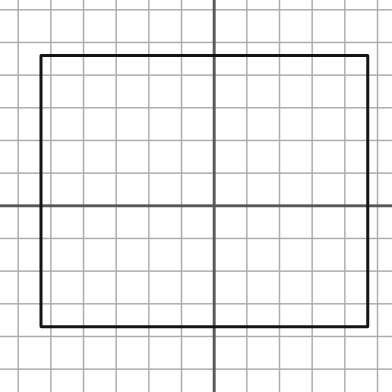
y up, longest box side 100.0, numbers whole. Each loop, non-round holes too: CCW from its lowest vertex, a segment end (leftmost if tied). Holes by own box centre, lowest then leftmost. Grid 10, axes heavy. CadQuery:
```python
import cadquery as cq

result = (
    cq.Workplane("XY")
    .moveTo(-53.0, -37.0)
    .lineTo(47.0, -37.0)
    .lineTo(47.0, 46.0)
    .lineTo(-53.0, 46.0)
    .close()
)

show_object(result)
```